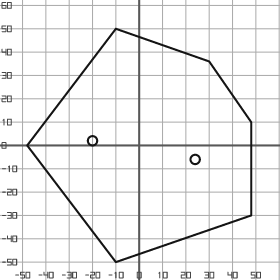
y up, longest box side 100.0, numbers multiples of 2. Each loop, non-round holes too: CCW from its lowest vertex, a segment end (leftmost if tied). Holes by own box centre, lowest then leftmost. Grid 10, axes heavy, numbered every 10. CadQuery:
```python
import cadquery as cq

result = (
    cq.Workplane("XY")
    .moveTo(-10.0, -50.0)
    .lineTo(48.0, -30.0)
    .lineTo(48.0, 10.0)
    .lineTo(30.0, 36.0)
    .lineTo(-10.0, 50.0)
    .lineTo(-48.0, 0.0)
    .close()
    .moveTo(24.0, -6.0)
    .circle(2.0)
    .moveTo(-20.0, 2.0)
    .circle(2.0)
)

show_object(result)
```